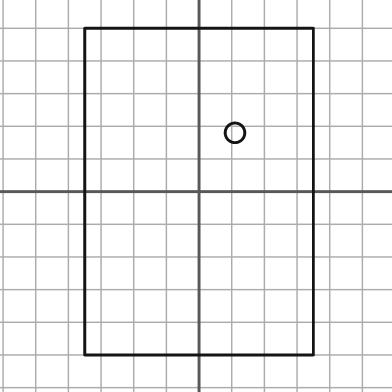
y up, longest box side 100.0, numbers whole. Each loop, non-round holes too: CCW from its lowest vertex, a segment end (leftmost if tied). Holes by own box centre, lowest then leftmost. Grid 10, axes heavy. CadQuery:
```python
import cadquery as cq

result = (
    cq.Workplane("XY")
    .moveTo(-35.0, -50.0)
    .lineTo(35.0, -50.0)
    .lineTo(35.0, 50.0)
    .lineTo(-35.0, 50.0)
    .close()
    .moveTo(11.0, 18.0)
    .circle(3.0)
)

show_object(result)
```